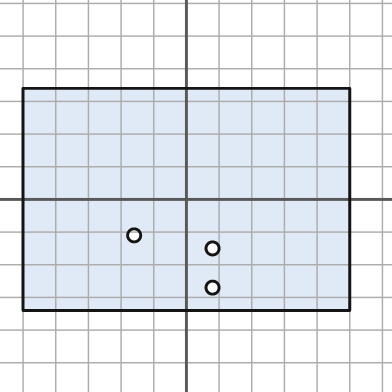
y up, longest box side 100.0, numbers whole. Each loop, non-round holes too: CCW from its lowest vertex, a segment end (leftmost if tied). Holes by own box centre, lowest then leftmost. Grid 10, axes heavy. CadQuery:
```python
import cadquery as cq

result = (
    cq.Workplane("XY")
    .moveTo(-50.0, -34.0)
    .lineTo(50.0, -34.0)
    .lineTo(50.0, 34.0)
    .lineTo(-50.0, 34.0)
    .close()
    .moveTo(8.0, -27.0)
    .circle(2.0)
    .moveTo(8.0, -15.0)
    .circle(2.0)
    .moveTo(-16.0, -11.0)
    .circle(2.0)
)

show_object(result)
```